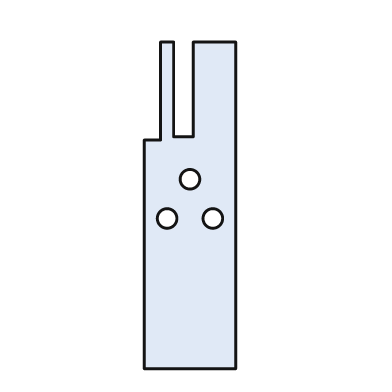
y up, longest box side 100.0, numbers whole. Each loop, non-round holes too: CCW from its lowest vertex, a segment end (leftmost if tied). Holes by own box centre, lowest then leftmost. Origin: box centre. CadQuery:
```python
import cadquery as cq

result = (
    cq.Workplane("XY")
    .moveTo(-14.0, -50.0)
    .lineTo(14.0, -50.0)
    .lineTo(14.0, 50.0)
    .lineTo(1.0, 50.0)
    .lineTo(1.0, 21.0)
    .lineTo(-5.0, 21.0)
    .lineTo(-5.0, 50.0)
    .lineTo(-9.0, 50.0)
    .lineTo(-9.0, 20.0)
    .lineTo(-14.0, 20.0)
    .close()
    .moveTo(-7.0, -4.0)
    .circle(3.0)
    .moveTo(7.0, -4.0)
    .circle(3.0)
    .moveTo(0.0, 8.0)
    .circle(3.0)
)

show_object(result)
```